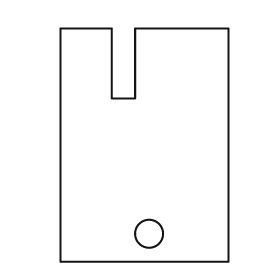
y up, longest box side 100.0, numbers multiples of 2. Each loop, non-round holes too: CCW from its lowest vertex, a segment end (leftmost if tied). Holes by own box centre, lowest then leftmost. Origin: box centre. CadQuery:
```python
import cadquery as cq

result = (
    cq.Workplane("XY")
    .moveTo(-36.0, -50.0)
    .lineTo(36.0, -50.0)
    .lineTo(36.0, 50.0)
    .lineTo(-4.0, 50.0)
    .lineTo(-4.0, 20.0)
    .lineTo(-14.0, 20.0)
    .lineTo(-14.0, 50.0)
    .lineTo(-36.0, 50.0)
    .close()
    .moveTo(2.0, -38.0)
    .circle(6.0)
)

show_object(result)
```